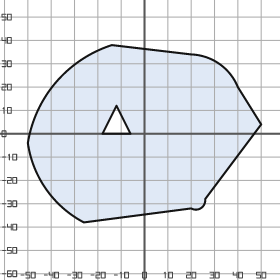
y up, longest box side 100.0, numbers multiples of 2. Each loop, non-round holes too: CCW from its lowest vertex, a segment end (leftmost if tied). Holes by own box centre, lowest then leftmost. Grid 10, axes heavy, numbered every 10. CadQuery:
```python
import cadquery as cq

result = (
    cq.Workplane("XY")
    .moveTo(-26.0, -38.0)
    .lineTo(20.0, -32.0)
    .threePointArc((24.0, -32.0), (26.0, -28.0))
    .lineTo(50.0, 4.0)
    .lineTo(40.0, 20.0)
    .threePointArc((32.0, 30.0), (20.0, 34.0))
    .lineTo(-14.0, 38.0)
    .threePointArc((-38.0, 22.0), (-50.0, -4.0))
    .threePointArc((-42.0, -24.0), (-26.0, -38.0))
    .close()
    .moveTo(-18.0, 0.0)
    .lineTo(-6.0, 0.0)
    .lineTo(-12.0, 12.0)
    .close()
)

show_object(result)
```